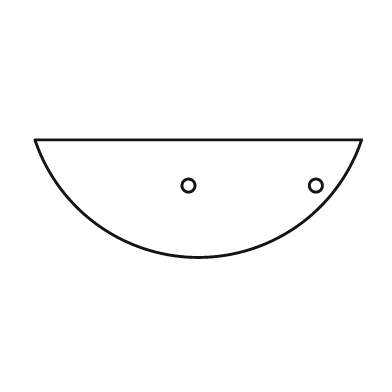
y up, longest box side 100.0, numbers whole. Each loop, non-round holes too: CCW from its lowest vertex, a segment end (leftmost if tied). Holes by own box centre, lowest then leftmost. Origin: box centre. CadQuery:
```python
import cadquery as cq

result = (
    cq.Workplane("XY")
    .moveTo(-50.0, 18.0)
    .threePointArc((0.0, -18.0), (50.0, 18.0))
    .close()
    .moveTo(-3.0, 4.0)
    .circle(2.0)
    .moveTo(36.0, 4.0)
    .circle(2.0)
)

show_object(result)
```